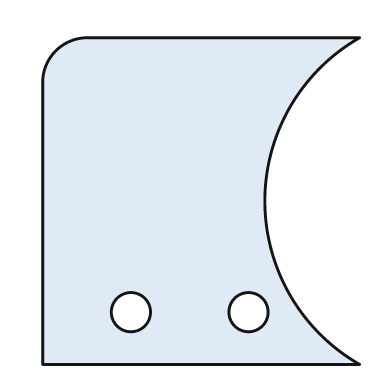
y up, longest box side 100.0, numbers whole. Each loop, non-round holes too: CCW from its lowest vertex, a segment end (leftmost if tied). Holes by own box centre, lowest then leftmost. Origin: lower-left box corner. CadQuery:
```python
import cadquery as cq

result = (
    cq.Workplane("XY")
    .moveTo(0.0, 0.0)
    .lineTo(97.0, 0.0)
    .threePointArc((68.0, 50.0), (97.0, 100.0))
    .lineTo(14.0, 100.0)
    .threePointArc((4.0, 96.0), (0.0, 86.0))
    .close()
    .moveTo(27.0, 16.0)
    .circle(6.0)
    .moveTo(63.0, 16.0)
    .circle(6.0)
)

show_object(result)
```